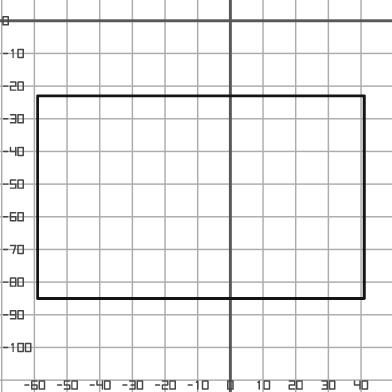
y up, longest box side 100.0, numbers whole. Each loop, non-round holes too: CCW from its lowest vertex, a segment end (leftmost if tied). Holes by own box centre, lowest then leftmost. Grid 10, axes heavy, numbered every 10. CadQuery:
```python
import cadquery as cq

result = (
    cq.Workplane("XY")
    .moveTo(-59.0, -85.0)
    .lineTo(41.0, -85.0)
    .lineTo(41.0, -23.0)
    .lineTo(-59.0, -23.0)
    .close()
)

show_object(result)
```